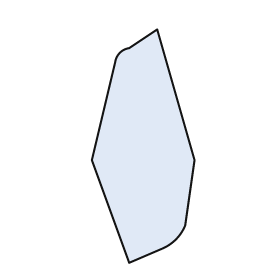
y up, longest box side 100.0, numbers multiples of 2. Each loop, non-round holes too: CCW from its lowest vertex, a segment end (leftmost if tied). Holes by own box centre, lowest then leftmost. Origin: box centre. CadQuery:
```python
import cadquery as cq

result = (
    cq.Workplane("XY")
    .moveTo(-6.0, -50.0)
    .lineTo(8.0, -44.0)
    .threePointArc((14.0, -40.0), (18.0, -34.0))
    .lineTo(22.0, -6.0)
    .lineTo(6.0, 50.0)
    .lineTo(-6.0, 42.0)
    .threePointArc((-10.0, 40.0), (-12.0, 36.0))
    .lineTo(-22.0, -6.0)
    .close()
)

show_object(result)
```